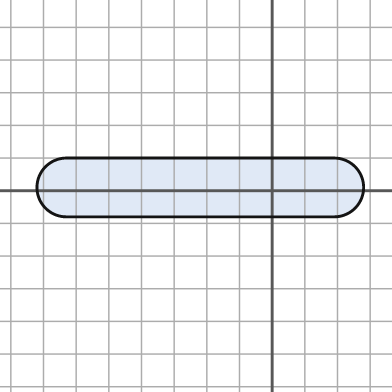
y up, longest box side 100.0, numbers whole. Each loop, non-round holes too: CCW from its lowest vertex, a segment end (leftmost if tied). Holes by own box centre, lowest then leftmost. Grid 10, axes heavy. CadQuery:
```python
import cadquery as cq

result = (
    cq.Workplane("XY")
    .moveTo(-63.0, -8.0)
    .lineTo(19.0, -8.0)
    .threePointArc((28.0, 1.0), (19.0, 10.0))
    .lineTo(-63.0, 10.0)
    .threePointArc((-72.0, 1.0), (-63.0, -8.0))
    .close()
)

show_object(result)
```